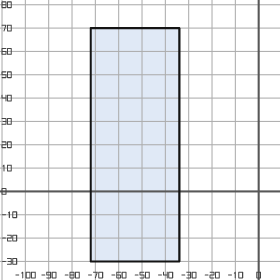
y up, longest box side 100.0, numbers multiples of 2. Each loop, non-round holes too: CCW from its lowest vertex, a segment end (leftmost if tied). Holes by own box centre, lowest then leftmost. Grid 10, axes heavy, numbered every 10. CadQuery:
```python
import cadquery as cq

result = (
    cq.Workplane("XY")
    .moveTo(-72.0, -30.0)
    .lineTo(-34.0, -30.0)
    .lineTo(-34.0, 70.0)
    .lineTo(-72.0, 70.0)
    .close()
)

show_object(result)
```